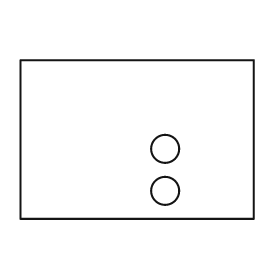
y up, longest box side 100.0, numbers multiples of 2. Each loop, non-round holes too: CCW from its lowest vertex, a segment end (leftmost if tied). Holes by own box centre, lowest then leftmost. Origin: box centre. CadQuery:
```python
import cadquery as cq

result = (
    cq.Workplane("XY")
    .moveTo(-50.0, -34.0)
    .lineTo(50.0, -34.0)
    .lineTo(50.0, 34.0)
    .lineTo(-50.0, 34.0)
    .close()
    .moveTo(12.0, -22.0)
    .circle(6.0)
    .moveTo(12.0, -4.0)
    .circle(6.0)
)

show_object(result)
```